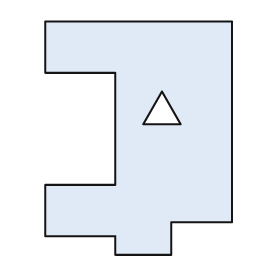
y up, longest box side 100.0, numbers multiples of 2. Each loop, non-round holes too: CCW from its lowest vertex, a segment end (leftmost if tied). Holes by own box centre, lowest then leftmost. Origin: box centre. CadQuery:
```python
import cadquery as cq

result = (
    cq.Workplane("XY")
    .moveTo(-10.0, -50.0)
    .lineTo(14.0, -50.0)
    .lineTo(14.0, -36.0)
    .lineTo(40.0, -36.0)
    .lineTo(40.0, 50.0)
    .lineTo(-40.0, 50.0)
    .lineTo(-40.0, 28.0)
    .lineTo(-10.0, 28.0)
    .lineTo(-10.0, -20.0)
    .lineTo(-40.0, -20.0)
    .lineTo(-40.0, -42.0)
    .lineTo(-10.0, -42.0)
    .close()
    .moveTo(2.0, 6.0)
    .lineTo(18.0, 6.0)
    .lineTo(10.0, 20.0)
    .close()
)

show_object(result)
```